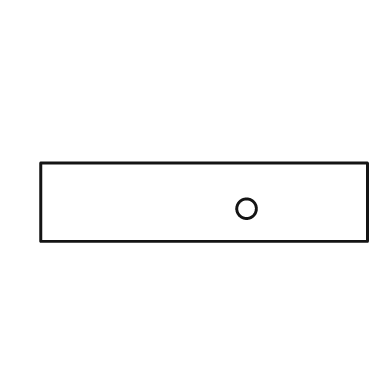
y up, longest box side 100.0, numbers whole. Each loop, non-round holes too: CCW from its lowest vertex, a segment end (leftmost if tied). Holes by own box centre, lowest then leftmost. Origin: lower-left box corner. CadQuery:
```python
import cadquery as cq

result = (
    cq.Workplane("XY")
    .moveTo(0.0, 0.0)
    .lineTo(100.0, 0.0)
    .lineTo(100.0, 24.0)
    .lineTo(0.0, 24.0)
    .close()
    .moveTo(63.0, 10.0)
    .circle(3.0)
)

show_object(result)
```